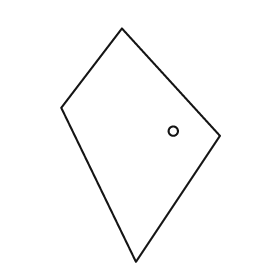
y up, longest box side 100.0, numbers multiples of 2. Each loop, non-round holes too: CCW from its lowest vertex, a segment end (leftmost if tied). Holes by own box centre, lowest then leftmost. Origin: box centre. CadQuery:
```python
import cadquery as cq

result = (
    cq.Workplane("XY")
    .moveTo(-2.0, -50.0)
    .lineTo(34.0, 4.0)
    .lineTo(-8.0, 50.0)
    .lineTo(-34.0, 16.0)
    .close()
    .moveTo(14.0, 6.0)
    .circle(2.0)
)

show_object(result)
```